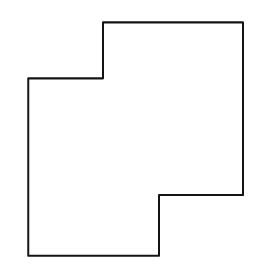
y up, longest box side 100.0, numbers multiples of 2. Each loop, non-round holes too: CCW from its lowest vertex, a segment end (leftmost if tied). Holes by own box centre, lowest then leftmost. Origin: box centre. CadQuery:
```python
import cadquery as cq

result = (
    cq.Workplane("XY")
    .moveTo(-46.0, -50.0)
    .lineTo(10.0, -50.0)
    .lineTo(10.0, -24.0)
    .lineTo(46.0, -24.0)
    .lineTo(46.0, 50.0)
    .lineTo(-14.0, 50.0)
    .lineTo(-14.0, 26.0)
    .lineTo(-46.0, 26.0)
    .close()
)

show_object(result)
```